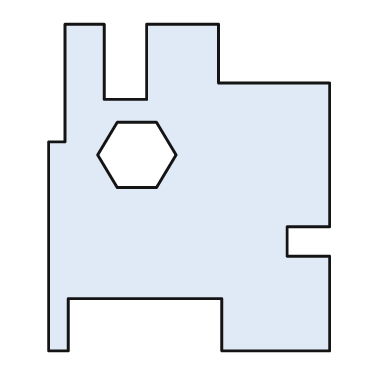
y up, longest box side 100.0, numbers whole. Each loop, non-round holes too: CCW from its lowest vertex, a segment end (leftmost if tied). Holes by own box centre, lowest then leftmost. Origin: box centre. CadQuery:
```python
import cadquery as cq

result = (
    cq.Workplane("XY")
    .moveTo(-43.0, -50.0)
    .lineTo(-37.0, -50.0)
    .lineTo(-37.0, -34.0)
    .lineTo(10.0, -34.0)
    .lineTo(10.0, -50.0)
    .lineTo(43.0, -50.0)
    .lineTo(43.0, -21.0)
    .lineTo(30.0, -21.0)
    .lineTo(30.0, -12.0)
    .lineTo(43.0, -12.0)
    .lineTo(43.0, 32.0)
    .lineTo(9.0, 32.0)
    .lineTo(9.0, 50.0)
    .lineTo(-13.0, 50.0)
    .lineTo(-13.0, 27.0)
    .lineTo(-26.0, 27.0)
    .lineTo(-26.0, 50.0)
    .lineTo(-38.0, 50.0)
    .lineTo(-38.0, 14.0)
    .lineTo(-43.0, 14.0)
    .close()
    .moveTo(-22.0, 0.0)
    .lineTo(-10.0, 0.0)
    .lineTo(-4.0, 10.0)
    .lineTo(-10.0, 20.0)
    .lineTo(-22.0, 20.0)
    .lineTo(-28.0, 10.0)
    .close()
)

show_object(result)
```